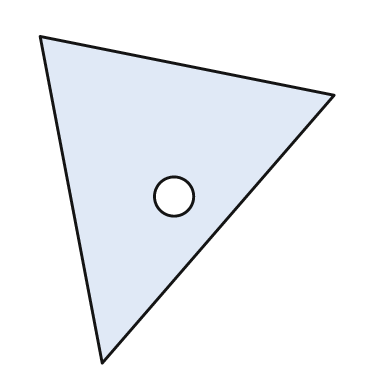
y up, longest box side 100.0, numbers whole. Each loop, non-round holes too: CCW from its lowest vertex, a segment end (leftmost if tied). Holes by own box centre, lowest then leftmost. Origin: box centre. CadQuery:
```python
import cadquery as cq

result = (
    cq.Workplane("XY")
    .moveTo(-26.0, -50.0)
    .lineTo(45.0, 32.0)
    .lineTo(-45.0, 50.0)
    .close()
    .moveTo(-4.0, 1.0)
    .circle(6.0)
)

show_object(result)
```